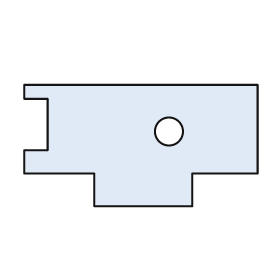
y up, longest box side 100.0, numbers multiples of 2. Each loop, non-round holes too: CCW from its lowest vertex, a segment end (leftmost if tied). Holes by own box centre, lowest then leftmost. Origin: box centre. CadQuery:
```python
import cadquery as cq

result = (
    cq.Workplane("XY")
    .moveTo(-20.0, -26.0)
    .lineTo(22.0, -26.0)
    .lineTo(22.0, -12.0)
    .lineTo(50.0, -12.0)
    .lineTo(50.0, 26.0)
    .lineTo(-50.0, 26.0)
    .lineTo(-50.0, 20.0)
    .lineTo(-40.0, 20.0)
    .lineTo(-40.0, -2.0)
    .lineTo(-50.0, -2.0)
    .lineTo(-50.0, -12.0)
    .lineTo(-20.0, -12.0)
    .close()
    .moveTo(12.0, 6.0)
    .circle(6.0)
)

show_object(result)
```